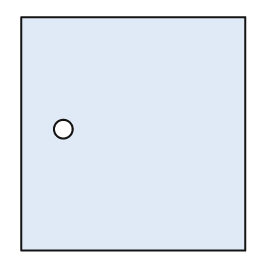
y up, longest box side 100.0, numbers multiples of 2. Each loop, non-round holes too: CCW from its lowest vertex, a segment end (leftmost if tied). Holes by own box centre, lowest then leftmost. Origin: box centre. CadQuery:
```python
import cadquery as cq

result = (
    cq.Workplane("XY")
    .moveTo(-48.0, -50.0)
    .lineTo(48.0, -50.0)
    .lineTo(48.0, 50.0)
    .lineTo(-48.0, 50.0)
    .close()
    .moveTo(-30.0, 2.0)
    .circle(4.0)
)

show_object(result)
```